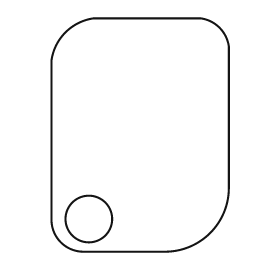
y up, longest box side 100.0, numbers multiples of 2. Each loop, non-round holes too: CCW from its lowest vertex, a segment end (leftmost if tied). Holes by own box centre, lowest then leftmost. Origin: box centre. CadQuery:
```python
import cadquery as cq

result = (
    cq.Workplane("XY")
    .moveTo(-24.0, -50.0)
    .lineTo(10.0, -50.0)
    .threePointArc((30.0, -42.0), (38.0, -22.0))
    .lineTo(38.0, 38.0)
    .threePointArc((34.0, 46.0), (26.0, 50.0))
    .lineTo(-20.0, 50.0)
    .threePointArc((-32.0, 44.0), (-38.0, 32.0))
    .lineTo(-38.0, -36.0)
    .threePointArc((-34.0, -46.0), (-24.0, -50.0))
    .close()
    .moveTo(-22.0, -36.0)
    .circle(10.0)
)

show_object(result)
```